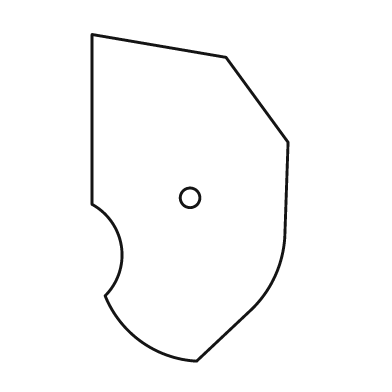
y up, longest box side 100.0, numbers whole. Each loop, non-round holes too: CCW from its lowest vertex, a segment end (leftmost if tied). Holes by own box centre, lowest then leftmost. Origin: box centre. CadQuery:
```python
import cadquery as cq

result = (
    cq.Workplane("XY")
    .moveTo(2.0, -50.0)
    .lineTo(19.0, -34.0)
    .threePointArc((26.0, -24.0), (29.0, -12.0))
    .lineTo(30.0, 17.0)
    .lineTo(11.0, 43.0)
    .lineTo(-30.0, 50.0)
    .lineTo(-30.0, -2.0)
    .threePointArc((-21.0, -15.0), (-26.0, -30.0))
    .threePointArc((-15.0, -44.0), (2.0, -50.0))
    .close()
    .moveTo(0.0, 0.0)
    .circle(3.0)
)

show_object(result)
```